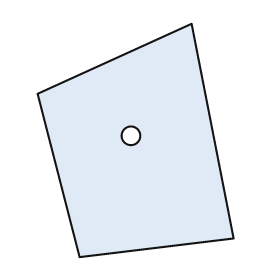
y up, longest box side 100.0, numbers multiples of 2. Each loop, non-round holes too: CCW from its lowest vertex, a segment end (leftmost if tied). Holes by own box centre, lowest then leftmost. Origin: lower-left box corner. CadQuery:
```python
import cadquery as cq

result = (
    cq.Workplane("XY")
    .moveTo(18.0, 0.0)
    .lineTo(84.0, 8.0)
    .lineTo(66.0, 100.0)
    .lineTo(0.0, 70.0)
    .close()
    .moveTo(40.0, 52.0)
    .circle(4.0)
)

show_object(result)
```